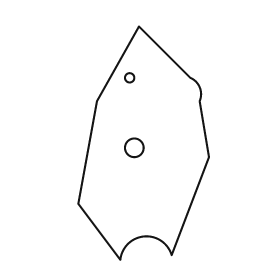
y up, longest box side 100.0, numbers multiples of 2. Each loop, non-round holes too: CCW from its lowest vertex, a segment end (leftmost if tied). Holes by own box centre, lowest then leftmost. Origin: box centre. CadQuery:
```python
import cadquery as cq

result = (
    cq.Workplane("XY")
    .moveTo(-10.0, -50.0)
    .threePointArc((0.0, -40.0), (12.0, -48.0))
    .lineTo(28.0, -6.0)
    .lineTo(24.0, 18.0)
    .threePointArc((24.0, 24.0), (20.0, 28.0))
    .lineTo(-2.0, 50.0)
    .lineTo(-20.0, 18.0)
    .lineTo(-28.0, -26.0)
    .close()
    .moveTo(-4.0, -2.0)
    .circle(4.0)
    .moveTo(-6.0, 28.0)
    .circle(2.0)
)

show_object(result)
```